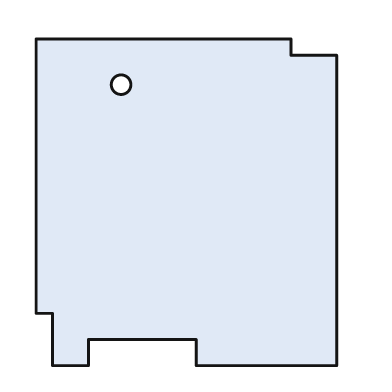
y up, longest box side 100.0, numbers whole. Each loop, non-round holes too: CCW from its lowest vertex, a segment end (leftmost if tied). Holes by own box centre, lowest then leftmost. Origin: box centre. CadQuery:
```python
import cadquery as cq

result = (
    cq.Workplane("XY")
    .moveTo(-41.0, -50.0)
    .lineTo(-30.0, -50.0)
    .lineTo(-30.0, -42.0)
    .lineTo(3.0, -42.0)
    .lineTo(3.0, -50.0)
    .lineTo(46.0, -50.0)
    .lineTo(46.0, 45.0)
    .lineTo(32.0, 45.0)
    .lineTo(32.0, 50.0)
    .lineTo(-46.0, 50.0)
    .lineTo(-46.0, -34.0)
    .lineTo(-41.0, -34.0)
    .close()
    .moveTo(-20.0, 36.0)
    .circle(3.0)
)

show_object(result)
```